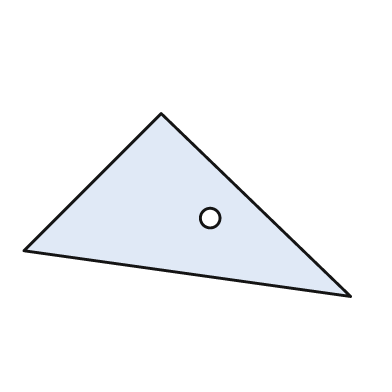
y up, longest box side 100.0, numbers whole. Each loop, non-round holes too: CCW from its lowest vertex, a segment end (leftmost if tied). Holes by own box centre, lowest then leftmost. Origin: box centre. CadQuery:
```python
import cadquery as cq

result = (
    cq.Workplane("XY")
    .moveTo(50.0, -28.0)
    .lineTo(-8.0, 28.0)
    .lineTo(-50.0, -14.0)
    .close()
    .moveTo(7.0, -4.0)
    .circle(3.0)
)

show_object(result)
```